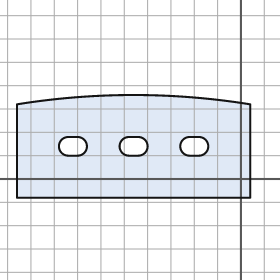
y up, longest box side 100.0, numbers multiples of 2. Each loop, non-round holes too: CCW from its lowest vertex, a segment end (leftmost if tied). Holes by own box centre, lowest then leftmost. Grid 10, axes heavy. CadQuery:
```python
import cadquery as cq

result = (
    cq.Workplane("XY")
    .moveTo(-96.0, -8.0)
    .lineTo(4.0, -8.0)
    .lineTo(4.0, 32.0)
    .threePointArc((-46.0, 36.0), (-96.0, 32.0))
    .close()
    .moveTo(-74.0, 10.0)
    .lineTo(-70.0, 10.0)
    .threePointArc((-66.0, 14.0), (-70.0, 18.0))
    .lineTo(-74.0, 18.0)
    .threePointArc((-78.0, 14.0), (-74.0, 10.0))
    .close()
    .moveTo(-48.0, 10.0)
    .lineTo(-44.0, 10.0)
    .threePointArc((-40.0, 14.0), (-44.0, 18.0))
    .lineTo(-48.0, 18.0)
    .threePointArc((-52.0, 14.0), (-48.0, 10.0))
    .close()
    .moveTo(-22.0, 10.0)
    .lineTo(-18.0, 10.0)
    .threePointArc((-14.0, 14.0), (-18.0, 18.0))
    .lineTo(-22.0, 18.0)
    .threePointArc((-26.0, 14.0), (-22.0, 10.0))
    .close()
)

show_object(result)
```